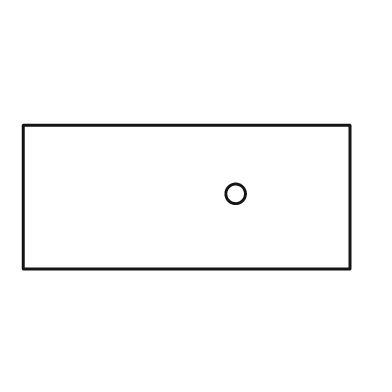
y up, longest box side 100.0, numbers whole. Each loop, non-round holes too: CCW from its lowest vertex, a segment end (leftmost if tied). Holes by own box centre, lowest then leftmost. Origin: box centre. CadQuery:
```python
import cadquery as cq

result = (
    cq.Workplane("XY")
    .moveTo(-50.0, -22.0)
    .lineTo(50.0, -22.0)
    .lineTo(50.0, 22.0)
    .lineTo(-50.0, 22.0)
    .close()
    .moveTo(15.0, 1.0)
    .circle(3.0)
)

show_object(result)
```